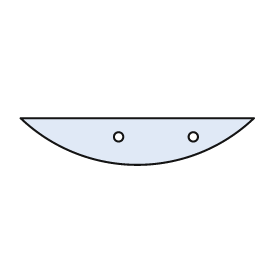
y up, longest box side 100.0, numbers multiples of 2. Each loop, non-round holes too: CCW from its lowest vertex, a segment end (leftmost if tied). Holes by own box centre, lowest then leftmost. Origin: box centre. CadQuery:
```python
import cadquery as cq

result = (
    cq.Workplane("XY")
    .moveTo(-50.0, 10.0)
    .threePointArc((0.0, -10.0), (50.0, 10.0))
    .close()
    .moveTo(-8.0, 2.0)
    .circle(2.0)
    .moveTo(24.0, 2.0)
    .circle(2.0)
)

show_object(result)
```